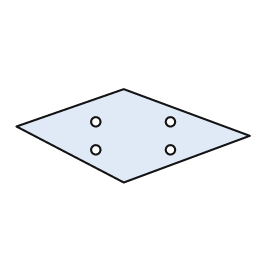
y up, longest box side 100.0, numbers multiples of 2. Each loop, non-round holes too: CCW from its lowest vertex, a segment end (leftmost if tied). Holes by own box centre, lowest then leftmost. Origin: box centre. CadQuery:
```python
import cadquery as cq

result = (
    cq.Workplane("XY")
    .moveTo(-4.0, -20.0)
    .lineTo(50.0, 0.0)
    .lineTo(-4.0, 20.0)
    .lineTo(-50.0, 4.0)
    .close()
    .moveTo(-16.0, -6.0)
    .circle(2.0)
    .moveTo(16.0, -6.0)
    .circle(2.0)
    .moveTo(-16.0, 6.0)
    .circle(2.0)
    .moveTo(16.0, 6.0)
    .circle(2.0)
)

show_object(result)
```